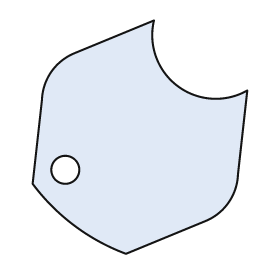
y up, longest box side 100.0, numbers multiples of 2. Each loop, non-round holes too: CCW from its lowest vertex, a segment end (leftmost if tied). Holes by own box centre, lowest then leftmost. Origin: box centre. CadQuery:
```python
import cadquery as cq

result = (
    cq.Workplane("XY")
    .moveTo(-6.0, -50.0)
    .lineTo(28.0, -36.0)
    .threePointArc((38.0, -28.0), (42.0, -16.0))
    .lineTo(46.0, 20.0)
    .threePointArc((16.0, 22.0), (6.0, 50.0))
    .lineTo(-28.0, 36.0)
    .threePointArc((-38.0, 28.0), (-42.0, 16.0))
    .lineTo(-46.0, -20.0)
    .threePointArc((-28.0, -38.0), (-6.0, -50.0))
    .close()
    .moveTo(-32.0, -14.0)
    .circle(6.0)
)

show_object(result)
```